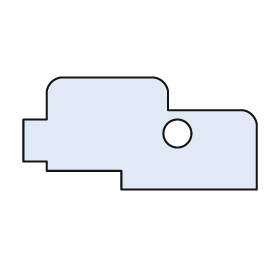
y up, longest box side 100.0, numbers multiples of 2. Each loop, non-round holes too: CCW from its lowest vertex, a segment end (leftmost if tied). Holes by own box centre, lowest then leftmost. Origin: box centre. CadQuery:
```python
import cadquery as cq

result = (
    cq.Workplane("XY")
    .moveTo(-8.0, -24.0)
    .lineTo(50.0, -24.0)
    .lineTo(50.0, 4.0)
    .threePointArc((48.0, 8.0), (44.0, 10.0))
    .lineTo(12.0, 10.0)
    .lineTo(12.0, 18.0)
    .threePointArc((10.0, 22.0), (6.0, 24.0))
    .lineTo(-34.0, 24.0)
    .threePointArc((-38.0, 22.0), (-40.0, 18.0))
    .lineTo(-40.0, 6.0)
    .lineTo(-50.0, 6.0)
    .lineTo(-50.0, -12.0)
    .lineTo(-40.0, -12.0)
    .lineTo(-40.0, -16.0)
    .lineTo(-8.0, -16.0)
    .close()
    .moveTo(16.0, 0.0)
    .circle(6.0)
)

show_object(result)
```